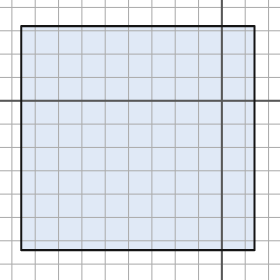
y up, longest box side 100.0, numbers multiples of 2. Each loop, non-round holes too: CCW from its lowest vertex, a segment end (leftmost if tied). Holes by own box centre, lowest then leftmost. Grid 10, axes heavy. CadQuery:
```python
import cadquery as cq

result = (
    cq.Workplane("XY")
    .moveTo(-86.0, -64.0)
    .lineTo(14.0, -64.0)
    .lineTo(14.0, 32.0)
    .lineTo(-86.0, 32.0)
    .close()
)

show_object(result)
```